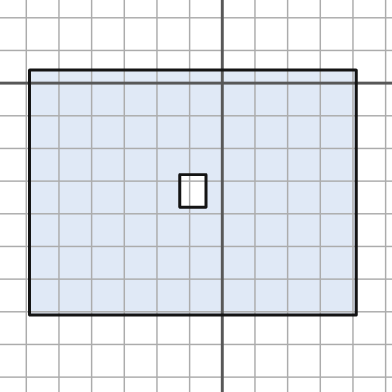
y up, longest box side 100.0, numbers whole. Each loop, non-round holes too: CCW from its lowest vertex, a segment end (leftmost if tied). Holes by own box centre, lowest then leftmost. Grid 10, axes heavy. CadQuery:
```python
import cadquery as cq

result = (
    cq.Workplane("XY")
    .moveTo(-59.0, -71.0)
    .lineTo(41.0, -71.0)
    .lineTo(41.0, 4.0)
    .lineTo(-59.0, 4.0)
    .close()
    .moveTo(-13.0, -38.0)
    .lineTo(-5.0, -38.0)
    .lineTo(-5.0, -28.0)
    .lineTo(-13.0, -28.0)
    .close()
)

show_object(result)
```